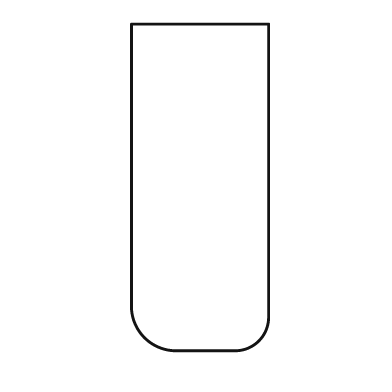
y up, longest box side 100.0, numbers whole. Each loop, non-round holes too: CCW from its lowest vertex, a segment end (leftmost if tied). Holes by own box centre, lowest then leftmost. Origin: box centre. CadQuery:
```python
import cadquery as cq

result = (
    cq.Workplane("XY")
    .moveTo(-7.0, -50.0)
    .lineTo(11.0, -50.0)
    .threePointArc((18.0, -47.0), (21.0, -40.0))
    .lineTo(21.0, 50.0)
    .lineTo(-21.0, 50.0)
    .lineTo(-21.0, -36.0)
    .threePointArc((-17.0, -46.0), (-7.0, -50.0))
    .close()
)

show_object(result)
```